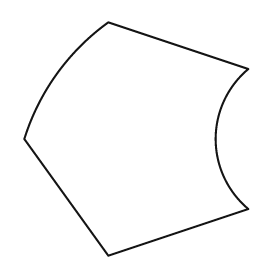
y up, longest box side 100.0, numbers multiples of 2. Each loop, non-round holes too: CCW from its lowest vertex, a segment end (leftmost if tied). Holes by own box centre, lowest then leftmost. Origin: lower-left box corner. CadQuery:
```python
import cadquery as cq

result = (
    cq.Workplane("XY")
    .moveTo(36.0, 0.0)
    .lineTo(96.0, 20.0)
    .threePointArc((82.0, 50.0), (96.0, 80.0))
    .lineTo(36.0, 100.0)
    .threePointArc((14.0, 78.0), (0.0, 50.0))
    .close()
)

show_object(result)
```